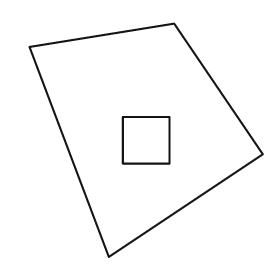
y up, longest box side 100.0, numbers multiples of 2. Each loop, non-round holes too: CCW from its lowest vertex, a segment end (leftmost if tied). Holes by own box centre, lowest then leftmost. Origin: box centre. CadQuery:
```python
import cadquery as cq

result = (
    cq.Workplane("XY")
    .moveTo(-16.0, -50.0)
    .lineTo(50.0, -6.0)
    .lineTo(12.0, 50.0)
    .lineTo(-50.0, 40.0)
    .close()
    .moveTo(-10.0, -10.0)
    .lineTo(10.0, -10.0)
    .lineTo(10.0, 10.0)
    .lineTo(-10.0, 10.0)
    .close()
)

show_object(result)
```